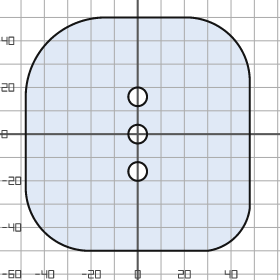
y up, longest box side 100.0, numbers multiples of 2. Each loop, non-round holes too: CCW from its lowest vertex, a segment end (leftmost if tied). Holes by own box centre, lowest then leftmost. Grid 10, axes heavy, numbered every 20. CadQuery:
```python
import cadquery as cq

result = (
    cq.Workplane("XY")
    .moveTo(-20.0, -50.0)
    .lineTo(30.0, -50.0)
    .threePointArc((42.0, -44.0), (48.0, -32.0))
    .lineTo(48.0, 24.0)
    .threePointArc((40.0, 42.0), (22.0, 50.0))
    .lineTo(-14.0, 50.0)
    .threePointArc((-38.0, 40.0), (-48.0, 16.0))
    .lineTo(-48.0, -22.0)
    .threePointArc((-40.0, -42.0), (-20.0, -50.0))
    .close()
    .moveTo(0.0, -16.0)
    .circle(4.0)
    .moveTo(0.0, 0.0)
    .circle(4.0)
    .moveTo(0.0, 16.0)
    .circle(4.0)
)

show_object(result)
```